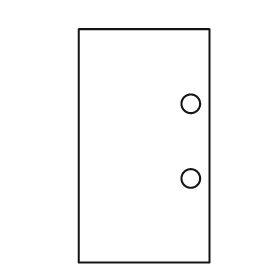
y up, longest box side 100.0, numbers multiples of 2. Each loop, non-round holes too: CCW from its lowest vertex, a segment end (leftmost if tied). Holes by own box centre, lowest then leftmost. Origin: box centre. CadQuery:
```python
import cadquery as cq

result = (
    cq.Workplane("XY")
    .moveTo(-28.0, -50.0)
    .lineTo(28.0, -50.0)
    .lineTo(28.0, 50.0)
    .lineTo(-28.0, 50.0)
    .close()
    .moveTo(20.0, -14.0)
    .circle(4.0)
    .moveTo(20.0, 18.0)
    .circle(4.0)
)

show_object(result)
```